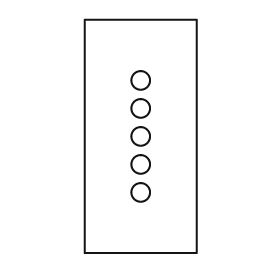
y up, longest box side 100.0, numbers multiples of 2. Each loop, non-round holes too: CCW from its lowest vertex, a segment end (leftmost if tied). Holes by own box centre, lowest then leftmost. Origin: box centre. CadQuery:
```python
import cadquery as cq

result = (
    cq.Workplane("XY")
    .moveTo(-24.0, -50.0)
    .lineTo(24.0, -50.0)
    .lineTo(24.0, 50.0)
    .lineTo(-24.0, 50.0)
    .close()
    .moveTo(0.0, -24.0)
    .circle(4.0)
    .moveTo(0.0, -12.0)
    .circle(4.0)
    .moveTo(0.0, 0.0)
    .circle(4.0)
    .moveTo(0.0, 12.0)
    .circle(4.0)
    .moveTo(0.0, 24.0)
    .circle(4.0)
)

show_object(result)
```